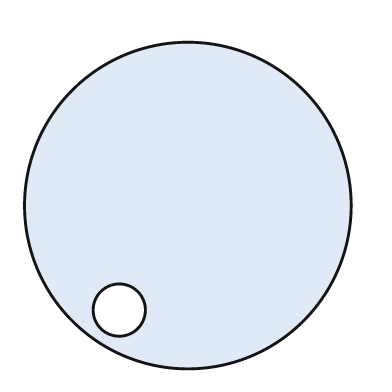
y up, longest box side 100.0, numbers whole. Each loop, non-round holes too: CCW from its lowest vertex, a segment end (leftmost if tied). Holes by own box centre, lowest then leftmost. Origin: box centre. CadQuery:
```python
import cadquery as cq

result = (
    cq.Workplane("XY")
    .moveTo(0.0, 0.0)
    .circle(50.0)
    .moveTo(-21.0, -32.0)
    .circle(8.0)
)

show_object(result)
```